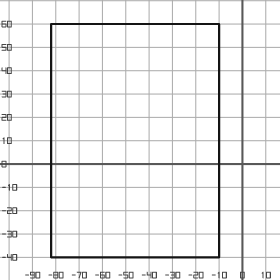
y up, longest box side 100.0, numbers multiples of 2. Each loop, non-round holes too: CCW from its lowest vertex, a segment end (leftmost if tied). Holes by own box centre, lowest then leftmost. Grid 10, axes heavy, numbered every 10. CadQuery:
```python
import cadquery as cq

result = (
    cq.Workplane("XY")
    .moveTo(-82.0, -40.0)
    .lineTo(-10.0, -40.0)
    .lineTo(-10.0, 60.0)
    .lineTo(-82.0, 60.0)
    .close()
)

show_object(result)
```